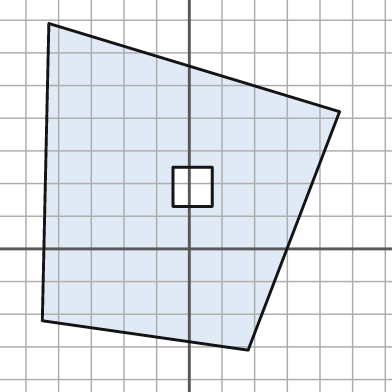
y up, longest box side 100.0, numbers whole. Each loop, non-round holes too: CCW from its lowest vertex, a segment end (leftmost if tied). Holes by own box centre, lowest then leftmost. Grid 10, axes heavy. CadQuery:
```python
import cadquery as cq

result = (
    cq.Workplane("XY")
    .moveTo(18.0, -31.0)
    .lineTo(46.0, 42.0)
    .lineTo(-43.0, 69.0)
    .lineTo(-45.0, -22.0)
    .close()
    .moveTo(-5.0, 13.0)
    .lineTo(7.0, 13.0)
    .lineTo(7.0, 25.0)
    .lineTo(-5.0, 25.0)
    .close()
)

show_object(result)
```